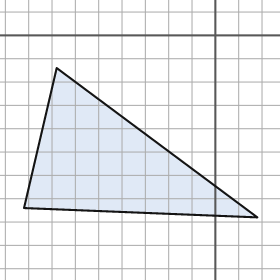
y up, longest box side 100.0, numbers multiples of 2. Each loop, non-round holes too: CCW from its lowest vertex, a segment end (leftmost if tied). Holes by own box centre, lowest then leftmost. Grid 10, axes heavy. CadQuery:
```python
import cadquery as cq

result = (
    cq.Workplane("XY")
    .moveTo(18.0, -78.0)
    .lineTo(-68.0, -14.0)
    .lineTo(-82.0, -74.0)
    .close()
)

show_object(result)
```